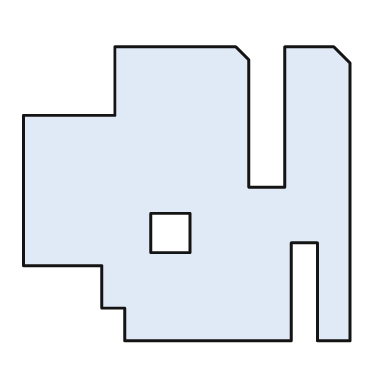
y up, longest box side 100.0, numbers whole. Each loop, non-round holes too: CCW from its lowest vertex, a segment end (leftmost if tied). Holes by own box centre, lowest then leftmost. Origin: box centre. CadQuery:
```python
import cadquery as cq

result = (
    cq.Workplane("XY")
    .moveTo(-19.0, -45.0)
    .lineTo(32.0, -45.0)
    .lineTo(32.0, -15.0)
    .lineTo(40.0, -15.0)
    .lineTo(40.0, -45.0)
    .lineTo(50.0, -45.0)
    .lineTo(50.0, 40.0)
    .lineTo(45.0, 45.0)
    .lineTo(30.0, 45.0)
    .lineTo(30.0, 2.0)
    .lineTo(19.0, 2.0)
    .lineTo(19.0, 41.0)
    .lineTo(15.0, 45.0)
    .lineTo(-22.0, 45.0)
    .lineTo(-22.0, 24.0)
    .lineTo(-50.0, 24.0)
    .lineTo(-50.0, -22.0)
    .lineTo(-26.0, -22.0)
    .lineTo(-26.0, -35.0)
    .lineTo(-19.0, -35.0)
    .close()
    .moveTo(-11.0, -18.0)
    .lineTo(1.0, -18.0)
    .lineTo(1.0, -6.0)
    .lineTo(-11.0, -6.0)
    .close()
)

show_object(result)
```